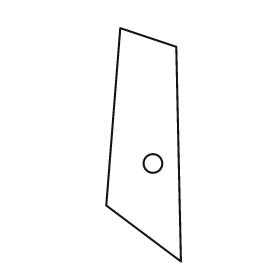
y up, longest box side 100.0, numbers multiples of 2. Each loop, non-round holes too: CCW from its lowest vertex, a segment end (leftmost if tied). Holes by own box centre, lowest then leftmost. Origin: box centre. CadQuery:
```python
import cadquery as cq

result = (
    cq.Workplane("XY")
    .moveTo(16.0, -50.0)
    .lineTo(14.0, 42.0)
    .lineTo(-10.0, 50.0)
    .lineTo(-16.0, -26.0)
    .close()
    .moveTo(4.0, -8.0)
    .circle(4.0)
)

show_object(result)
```